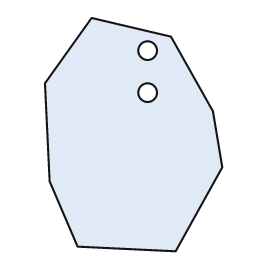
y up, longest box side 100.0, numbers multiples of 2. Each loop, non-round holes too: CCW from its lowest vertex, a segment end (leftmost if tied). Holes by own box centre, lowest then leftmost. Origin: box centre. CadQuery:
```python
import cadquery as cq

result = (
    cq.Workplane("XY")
    .moveTo(18.0, -50.0)
    .lineTo(38.0, -14.0)
    .lineTo(34.0, 10.0)
    .lineTo(16.0, 42.0)
    .lineTo(-18.0, 50.0)
    .lineTo(-38.0, 22.0)
    .lineTo(-36.0, -20.0)
    .lineTo(-24.0, -48.0)
    .close()
    .moveTo(6.0, 18.0)
    .circle(4.0)
    .moveTo(6.0, 36.0)
    .circle(4.0)
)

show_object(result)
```